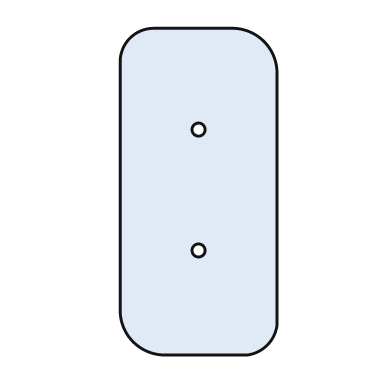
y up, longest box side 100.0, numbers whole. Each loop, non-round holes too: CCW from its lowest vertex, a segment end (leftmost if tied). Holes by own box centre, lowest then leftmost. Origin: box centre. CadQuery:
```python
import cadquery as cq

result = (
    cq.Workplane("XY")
    .moveTo(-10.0, -50.0)
    .lineTo(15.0, -50.0)
    .threePointArc((21.0, -47.0), (24.0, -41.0))
    .lineTo(24.0, 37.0)
    .threePointArc((20.0, 46.0), (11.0, 50.0))
    .lineTo(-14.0, 50.0)
    .threePointArc((-21.0, 47.0), (-24.0, 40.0))
    .lineTo(-24.0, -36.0)
    .threePointArc((-20.0, -46.0), (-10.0, -50.0))
    .close()
    .moveTo(0.0, -18.0)
    .circle(2.0)
    .moveTo(0.0, 19.0)
    .circle(2.0)
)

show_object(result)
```